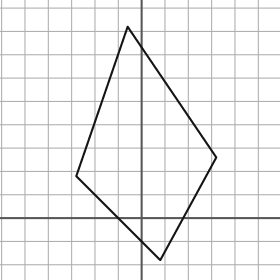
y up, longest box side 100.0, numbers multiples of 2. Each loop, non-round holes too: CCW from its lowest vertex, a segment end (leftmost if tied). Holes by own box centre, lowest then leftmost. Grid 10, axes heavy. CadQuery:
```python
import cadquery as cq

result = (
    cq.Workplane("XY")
    .moveTo(8.0, -18.0)
    .lineTo(32.0, 26.0)
    .lineTo(-6.0, 82.0)
    .lineTo(-28.0, 18.0)
    .close()
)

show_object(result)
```